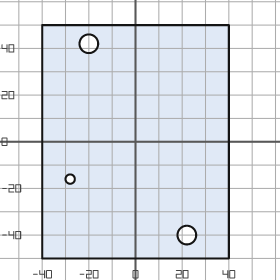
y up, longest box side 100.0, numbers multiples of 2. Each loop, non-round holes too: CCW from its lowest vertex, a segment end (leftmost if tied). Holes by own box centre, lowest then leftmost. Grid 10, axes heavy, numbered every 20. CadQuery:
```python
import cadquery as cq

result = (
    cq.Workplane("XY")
    .moveTo(-40.0, -50.0)
    .lineTo(40.0, -50.0)
    .lineTo(40.0, 50.0)
    .lineTo(-40.0, 50.0)
    .close()
    .moveTo(22.0, -40.0)
    .circle(4.0)
    .moveTo(-28.0, -16.0)
    .circle(2.0)
    .moveTo(-20.0, 42.0)
    .circle(4.0)
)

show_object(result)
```